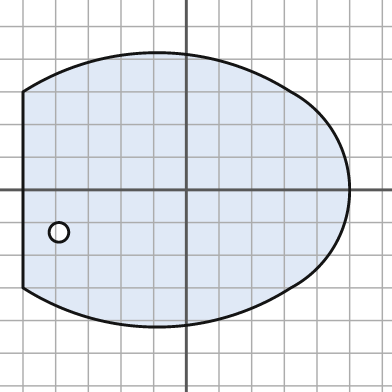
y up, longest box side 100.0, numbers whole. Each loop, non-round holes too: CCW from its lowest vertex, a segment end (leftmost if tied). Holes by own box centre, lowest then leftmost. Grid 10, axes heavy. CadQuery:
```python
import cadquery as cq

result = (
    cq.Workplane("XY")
    .moveTo(-50.0, -30.0)
    .threePointArc((-9.0, -42.0), (32.0, -30.0))
    .threePointArc((50.0, 0.0), (32.0, 30.0))
    .threePointArc((-9.0, 42.0), (-50.0, 30.0))
    .close()
    .moveTo(-39.0, -13.0)
    .circle(3.0)
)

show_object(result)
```